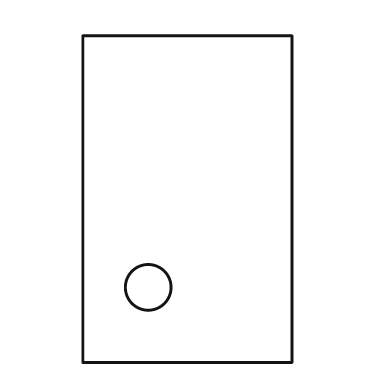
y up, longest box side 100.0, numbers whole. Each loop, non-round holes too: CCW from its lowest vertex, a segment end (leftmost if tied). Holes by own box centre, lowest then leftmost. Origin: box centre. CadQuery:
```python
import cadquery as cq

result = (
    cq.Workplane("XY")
    .moveTo(-32.0, -50.0)
    .lineTo(32.0, -50.0)
    .lineTo(32.0, 50.0)
    .lineTo(-32.0, 50.0)
    .close()
    .moveTo(-12.0, -27.0)
    .circle(7.0)
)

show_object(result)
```